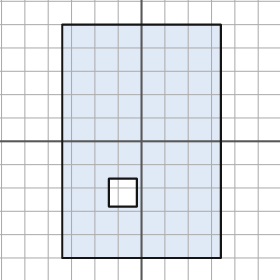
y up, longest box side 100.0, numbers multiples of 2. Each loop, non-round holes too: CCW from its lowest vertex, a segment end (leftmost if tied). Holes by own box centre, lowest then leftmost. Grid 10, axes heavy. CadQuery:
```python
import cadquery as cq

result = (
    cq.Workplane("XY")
    .moveTo(-34.0, -50.0)
    .lineTo(34.0, -50.0)
    .lineTo(34.0, 50.0)
    .lineTo(-34.0, 50.0)
    .close()
    .moveTo(-14.0, -28.0)
    .lineTo(-2.0, -28.0)
    .lineTo(-2.0, -16.0)
    .lineTo(-14.0, -16.0)
    .close()
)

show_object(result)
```